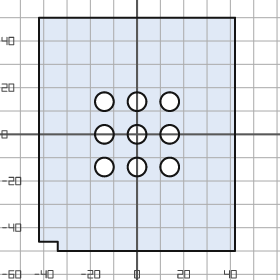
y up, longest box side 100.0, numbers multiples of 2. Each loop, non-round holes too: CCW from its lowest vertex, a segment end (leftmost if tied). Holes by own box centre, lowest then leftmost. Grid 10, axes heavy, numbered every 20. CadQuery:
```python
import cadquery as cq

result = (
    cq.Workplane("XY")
    .moveTo(-34.0, -50.0)
    .lineTo(42.0, -50.0)
    .lineTo(42.0, 50.0)
    .lineTo(-42.0, 50.0)
    .lineTo(-42.0, -46.0)
    .lineTo(-34.0, -46.0)
    .close()
    .moveTo(-14.0, -14.0)
    .circle(4.0)
    .moveTo(0.0, -14.0)
    .circle(4.0)
    .moveTo(14.0, -14.0)
    .circle(4.0)
    .moveTo(-14.0, 0.0)
    .circle(4.0)
    .moveTo(0.0, 0.0)
    .circle(4.0)
    .moveTo(14.0, 0.0)
    .circle(4.0)
    .moveTo(-14.0, 14.0)
    .circle(4.0)
    .moveTo(0.0, 14.0)
    .circle(4.0)
    .moveTo(14.0, 14.0)
    .circle(4.0)
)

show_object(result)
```